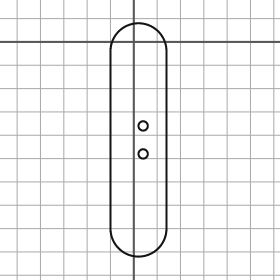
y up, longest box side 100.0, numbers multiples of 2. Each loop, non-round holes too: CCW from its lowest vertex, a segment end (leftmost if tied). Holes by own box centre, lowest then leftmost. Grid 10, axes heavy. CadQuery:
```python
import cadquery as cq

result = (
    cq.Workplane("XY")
    .moveTo(-10.0, -80.0)
    .threePointArc((2.0, -92.0), (14.0, -80.0))
    .lineTo(14.0, -4.0)
    .threePointArc((2.0, 8.0), (-10.0, -4.0))
    .close()
    .moveTo(4.0, -48.0)
    .circle(2.0)
    .moveTo(4.0, -36.0)
    .circle(2.0)
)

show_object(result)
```